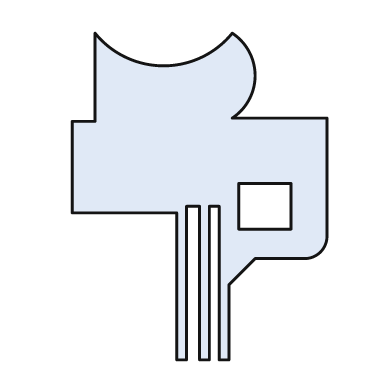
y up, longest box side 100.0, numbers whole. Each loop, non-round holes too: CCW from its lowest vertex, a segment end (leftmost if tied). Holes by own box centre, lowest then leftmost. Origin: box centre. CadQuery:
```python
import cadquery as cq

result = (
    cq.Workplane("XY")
    .moveTo(-7.0, -50.0)
    .lineTo(-4.0, -50.0)
    .lineTo(-4.0, -3.0)
    .lineTo(0.0, -3.0)
    .lineTo(0.0, -50.0)
    .lineTo(3.0, -50.0)
    .lineTo(3.0, -3.0)
    .lineTo(6.0, -3.0)
    .lineTo(6.0, -50.0)
    .lineTo(9.0, -50.0)
    .lineTo(9.0, -27.0)
    .lineTo(17.0, -19.0)
    .lineTo(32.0, -19.0)
    .threePointArc((37.0, -17.0), (39.0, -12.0))
    .lineTo(39.0, 24.0)
    .lineTo(10.0, 24.0)
    .threePointArc((17.0, 37.0), (10.0, 50.0))
    .threePointArc((-11.0, 40.0), (-32.0, 50.0))
    .lineTo(-32.0, 23.0)
    .lineTo(-39.0, 23.0)
    .lineTo(-39.0, -5.0)
    .lineTo(-7.0, -5.0)
    .close()
    .moveTo(12.0, -10.0)
    .lineTo(28.0, -10.0)
    .lineTo(28.0, 4.0)
    .lineTo(12.0, 4.0)
    .close()
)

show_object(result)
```